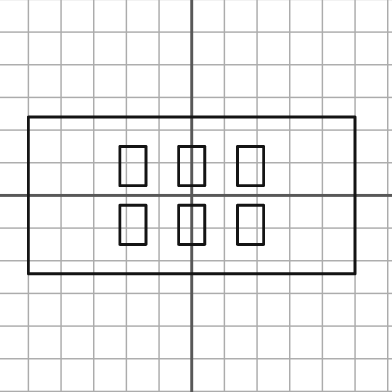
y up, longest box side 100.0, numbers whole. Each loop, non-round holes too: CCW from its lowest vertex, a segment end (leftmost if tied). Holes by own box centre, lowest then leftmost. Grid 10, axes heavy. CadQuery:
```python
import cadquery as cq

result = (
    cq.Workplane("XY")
    .moveTo(-50.0, -24.0)
    .lineTo(50.0, -24.0)
    .lineTo(50.0, 24.0)
    .lineTo(-50.0, 24.0)
    .close()
    .moveTo(-22.0, -15.0)
    .lineTo(-14.0, -15.0)
    .lineTo(-14.0, -3.0)
    .lineTo(-22.0, -3.0)
    .close()
    .moveTo(-4.0, -15.0)
    .lineTo(4.0, -15.0)
    .lineTo(4.0, -3.0)
    .lineTo(-4.0, -3.0)
    .close()
    .moveTo(14.0, -15.0)
    .lineTo(22.0, -15.0)
    .lineTo(22.0, -3.0)
    .lineTo(14.0, -3.0)
    .close()
    .moveTo(-22.0, 3.0)
    .lineTo(-14.0, 3.0)
    .lineTo(-14.0, 15.0)
    .lineTo(-22.0, 15.0)
    .close()
    .moveTo(-4.0, 3.0)
    .lineTo(4.0, 3.0)
    .lineTo(4.0, 15.0)
    .lineTo(-4.0, 15.0)
    .close()
    .moveTo(14.0, 3.0)
    .lineTo(22.0, 3.0)
    .lineTo(22.0, 15.0)
    .lineTo(14.0, 15.0)
    .close()
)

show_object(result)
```